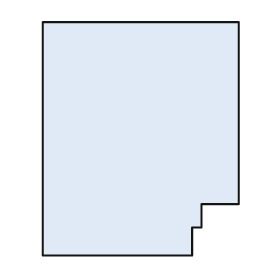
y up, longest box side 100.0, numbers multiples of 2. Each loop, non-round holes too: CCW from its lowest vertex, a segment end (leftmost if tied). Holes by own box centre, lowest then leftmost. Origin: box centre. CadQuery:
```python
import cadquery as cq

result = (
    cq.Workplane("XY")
    .moveTo(-42.0, -50.0)
    .lineTo(22.0, -50.0)
    .lineTo(22.0, -38.0)
    .lineTo(26.0, -38.0)
    .lineTo(26.0, -28.0)
    .lineTo(42.0, -28.0)
    .lineTo(42.0, 50.0)
    .lineTo(-42.0, 50.0)
    .close()
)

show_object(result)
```